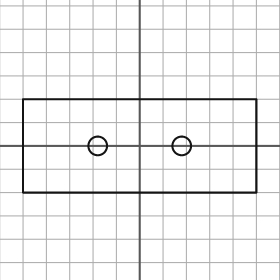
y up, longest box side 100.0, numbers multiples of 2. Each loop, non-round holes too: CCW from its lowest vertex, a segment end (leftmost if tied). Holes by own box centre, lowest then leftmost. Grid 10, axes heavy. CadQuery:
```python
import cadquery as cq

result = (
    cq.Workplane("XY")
    .moveTo(-50.0, -20.0)
    .lineTo(50.0, -20.0)
    .lineTo(50.0, 20.0)
    .lineTo(-50.0, 20.0)
    .close()
    .moveTo(-18.0, 0.0)
    .circle(4.0)
    .moveTo(18.0, 0.0)
    .circle(4.0)
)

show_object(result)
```